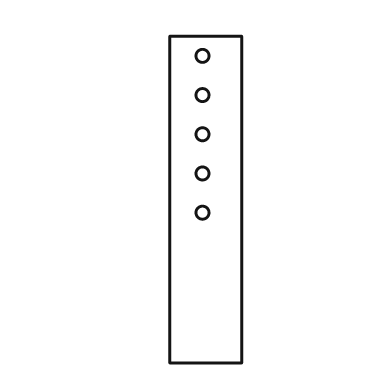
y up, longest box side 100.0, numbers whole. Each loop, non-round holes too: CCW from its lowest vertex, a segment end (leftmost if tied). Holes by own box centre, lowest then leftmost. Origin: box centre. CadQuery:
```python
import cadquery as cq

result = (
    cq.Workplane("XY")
    .moveTo(-11.0, -50.0)
    .lineTo(11.0, -50.0)
    .lineTo(11.0, 50.0)
    .lineTo(-11.0, 50.0)
    .close()
    .moveTo(-1.0, -4.0)
    .circle(2.0)
    .moveTo(-1.0, 8.0)
    .circle(2.0)
    .moveTo(-1.0, 20.0)
    .circle(2.0)
    .moveTo(-1.0, 32.0)
    .circle(2.0)
    .moveTo(-1.0, 44.0)
    .circle(2.0)
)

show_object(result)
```